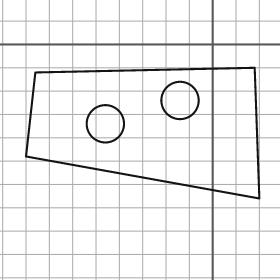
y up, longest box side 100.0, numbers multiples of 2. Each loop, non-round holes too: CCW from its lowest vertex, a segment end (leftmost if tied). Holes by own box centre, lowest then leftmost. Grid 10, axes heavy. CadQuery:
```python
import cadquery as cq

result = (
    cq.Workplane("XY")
    .moveTo(20.0, -66.0)
    .lineTo(18.0, -10.0)
    .lineTo(-76.0, -12.0)
    .lineTo(-80.0, -48.0)
    .close()
    .moveTo(-46.0, -34.0)
    .circle(8.0)
    .moveTo(-14.0, -24.0)
    .circle(8.0)
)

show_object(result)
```